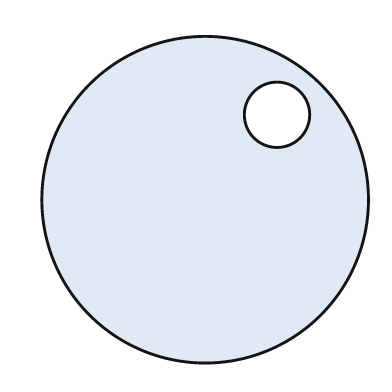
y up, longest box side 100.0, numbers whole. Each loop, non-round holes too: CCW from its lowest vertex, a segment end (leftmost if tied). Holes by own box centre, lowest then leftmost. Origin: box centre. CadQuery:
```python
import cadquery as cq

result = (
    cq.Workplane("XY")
    .moveTo(0.0, 0.0)
    .circle(50.0)
    .moveTo(22.0, 26.0)
    .circle(10.0)
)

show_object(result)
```